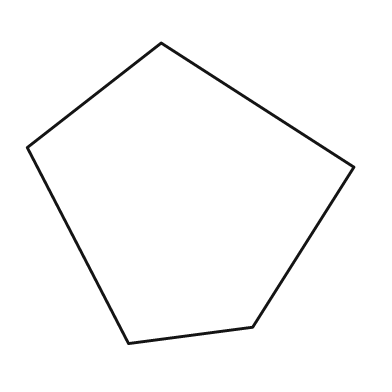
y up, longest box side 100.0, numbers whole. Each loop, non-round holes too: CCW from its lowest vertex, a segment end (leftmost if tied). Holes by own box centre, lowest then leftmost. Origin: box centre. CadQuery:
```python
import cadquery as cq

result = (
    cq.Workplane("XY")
    .moveTo(-19.0, -46.0)
    .lineTo(19.0, -41.0)
    .lineTo(50.0, 8.0)
    .lineTo(-9.0, 46.0)
    .lineTo(-50.0, 14.0)
    .close()
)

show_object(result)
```